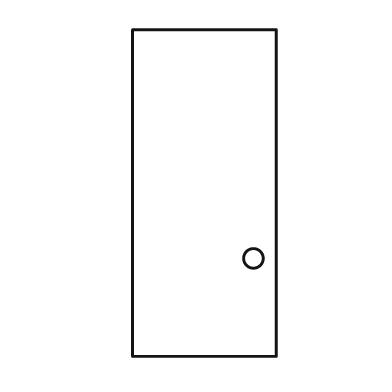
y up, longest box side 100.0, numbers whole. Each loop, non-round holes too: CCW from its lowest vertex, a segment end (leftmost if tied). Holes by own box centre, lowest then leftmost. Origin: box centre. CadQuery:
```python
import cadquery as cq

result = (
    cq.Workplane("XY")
    .moveTo(-22.0, -50.0)
    .lineTo(22.0, -50.0)
    .lineTo(22.0, 50.0)
    .lineTo(-22.0, 50.0)
    .close()
    .moveTo(15.0, -20.0)
    .circle(3.0)
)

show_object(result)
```